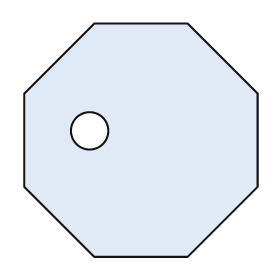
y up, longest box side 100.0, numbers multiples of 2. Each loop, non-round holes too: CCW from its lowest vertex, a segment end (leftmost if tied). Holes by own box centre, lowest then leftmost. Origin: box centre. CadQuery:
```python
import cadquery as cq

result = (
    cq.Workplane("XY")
    .moveTo(-20.0, -50.0)
    .lineTo(20.0, -50.0)
    .lineTo(50.0, -20.0)
    .lineTo(50.0, 20.0)
    .lineTo(20.0, 50.0)
    .lineTo(-20.0, 50.0)
    .lineTo(-50.0, 20.0)
    .lineTo(-50.0, -20.0)
    .close()
    .moveTo(-22.0, 4.0)
    .circle(8.0)
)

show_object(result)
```